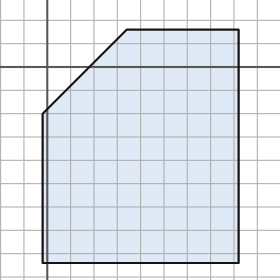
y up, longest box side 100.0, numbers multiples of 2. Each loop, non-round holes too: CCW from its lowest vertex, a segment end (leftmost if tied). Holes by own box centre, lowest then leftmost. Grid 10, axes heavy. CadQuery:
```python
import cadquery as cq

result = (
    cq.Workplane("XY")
    .moveTo(-2.0, -84.0)
    .lineTo(82.0, -84.0)
    .lineTo(82.0, 16.0)
    .lineTo(34.0, 16.0)
    .lineTo(-2.0, -20.0)
    .close()
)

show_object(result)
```